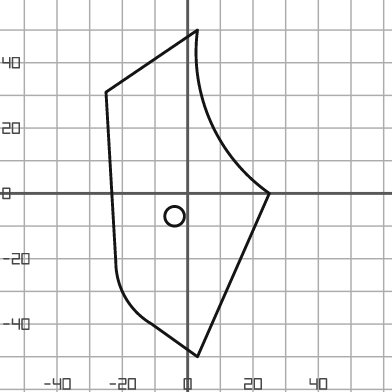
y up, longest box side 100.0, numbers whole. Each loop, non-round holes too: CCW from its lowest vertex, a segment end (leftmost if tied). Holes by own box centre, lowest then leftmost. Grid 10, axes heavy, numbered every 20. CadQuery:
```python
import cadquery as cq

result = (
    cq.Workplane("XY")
    .moveTo(3.0, -50.0)
    .lineTo(25.0, 0.0)
    .threePointArc((7.0, 22.0), (3.0, 50.0))
    .lineTo(-25.0, 31.0)
    .lineTo(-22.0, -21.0)
    .threePointArc((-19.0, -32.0), (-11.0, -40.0))
    .close()
    .moveTo(-4.0, -7.0)
    .circle(3.0)
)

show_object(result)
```